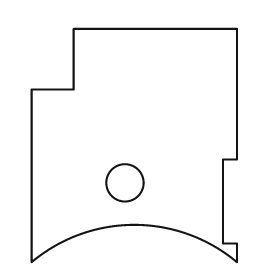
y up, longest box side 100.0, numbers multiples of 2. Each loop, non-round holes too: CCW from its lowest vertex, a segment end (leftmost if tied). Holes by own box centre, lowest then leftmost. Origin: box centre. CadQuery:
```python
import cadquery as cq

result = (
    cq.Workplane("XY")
    .moveTo(-44.0, -50.0)
    .threePointArc((0.0, -34.0), (44.0, -50.0))
    .lineTo(44.0, -42.0)
    .lineTo(38.0, -42.0)
    .lineTo(38.0, -6.0)
    .lineTo(44.0, -6.0)
    .lineTo(44.0, 50.0)
    .lineTo(-26.0, 50.0)
    .lineTo(-26.0, 24.0)
    .lineTo(-44.0, 24.0)
    .close()
    .moveTo(-4.0, -16.0)
    .circle(8.0)
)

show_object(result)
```